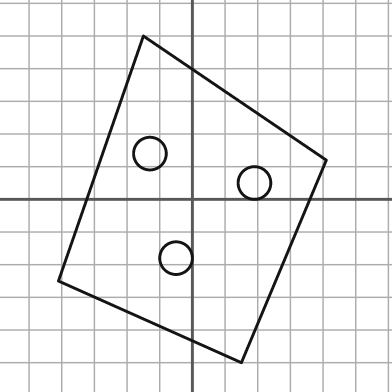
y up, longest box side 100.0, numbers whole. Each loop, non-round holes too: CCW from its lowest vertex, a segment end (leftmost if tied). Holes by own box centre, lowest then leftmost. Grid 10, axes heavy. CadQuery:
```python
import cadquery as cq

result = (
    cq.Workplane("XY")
    .moveTo(15.0, -50.0)
    .lineTo(41.0, 12.0)
    .lineTo(-15.0, 50.0)
    .lineTo(-41.0, -25.0)
    .close()
    .moveTo(-5.0, -18.0)
    .circle(5.0)
    .moveTo(19.0, 5.0)
    .circle(5.0)
    .moveTo(-13.0, 14.0)
    .circle(5.0)
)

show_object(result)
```